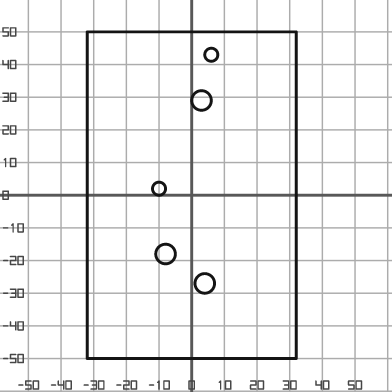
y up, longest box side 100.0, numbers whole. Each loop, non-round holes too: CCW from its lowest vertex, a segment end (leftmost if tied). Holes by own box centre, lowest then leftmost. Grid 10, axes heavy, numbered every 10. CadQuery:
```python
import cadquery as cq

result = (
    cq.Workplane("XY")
    .moveTo(-32.0, -50.0)
    .lineTo(32.0, -50.0)
    .lineTo(32.0, 50.0)
    .lineTo(-32.0, 50.0)
    .close()
    .moveTo(4.0, -27.0)
    .circle(3.0)
    .moveTo(-8.0, -18.0)
    .circle(3.0)
    .moveTo(-10.0, 2.0)
    .circle(2.0)
    .moveTo(3.0, 29.0)
    .circle(3.0)
    .moveTo(6.0, 43.0)
    .circle(2.0)
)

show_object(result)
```